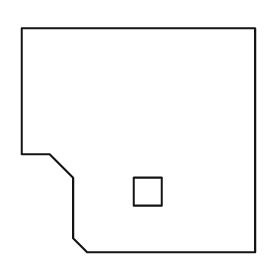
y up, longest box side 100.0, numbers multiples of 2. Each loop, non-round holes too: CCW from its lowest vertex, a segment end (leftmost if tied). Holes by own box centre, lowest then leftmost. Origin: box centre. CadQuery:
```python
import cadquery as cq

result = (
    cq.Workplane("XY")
    .moveTo(-22.0, -48.0)
    .lineTo(50.0, -48.0)
    .lineTo(50.0, 48.0)
    .lineTo(-50.0, 48.0)
    .lineTo(-50.0, -6.0)
    .lineTo(-38.0, -6.0)
    .lineTo(-28.0, -16.0)
    .lineTo(-28.0, -42.0)
    .close()
    .moveTo(-2.0, -28.0)
    .lineTo(10.0, -28.0)
    .lineTo(10.0, -16.0)
    .lineTo(-2.0, -16.0)
    .close()
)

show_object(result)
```